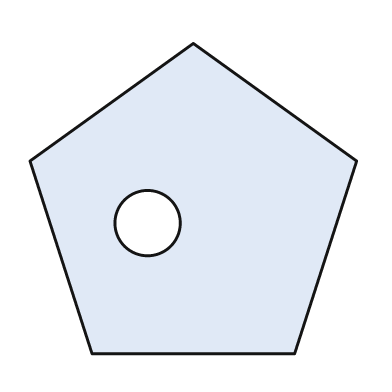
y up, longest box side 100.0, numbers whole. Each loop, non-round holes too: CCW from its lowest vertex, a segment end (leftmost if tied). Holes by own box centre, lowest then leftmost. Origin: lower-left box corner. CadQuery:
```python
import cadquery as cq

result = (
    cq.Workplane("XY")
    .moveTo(19.0, 0.0)
    .lineTo(81.0, 0.0)
    .lineTo(100.0, 59.0)
    .lineTo(50.0, 95.0)
    .lineTo(0.0, 59.0)
    .close()
    .moveTo(36.0, 40.0)
    .circle(10.0)
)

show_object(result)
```